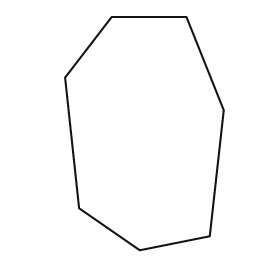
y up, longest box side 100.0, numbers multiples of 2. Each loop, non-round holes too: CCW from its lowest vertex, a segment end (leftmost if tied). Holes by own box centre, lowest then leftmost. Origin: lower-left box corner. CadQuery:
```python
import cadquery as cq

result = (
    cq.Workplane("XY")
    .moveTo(32.0, 0.0)
    .lineTo(62.0, 6.0)
    .lineTo(68.0, 60.0)
    .lineTo(52.0, 100.0)
    .lineTo(20.0, 100.0)
    .lineTo(0.0, 74.0)
    .lineTo(6.0, 18.0)
    .close()
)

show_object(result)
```